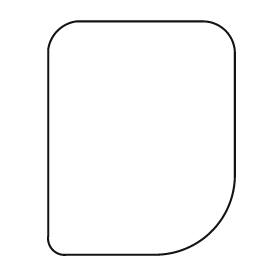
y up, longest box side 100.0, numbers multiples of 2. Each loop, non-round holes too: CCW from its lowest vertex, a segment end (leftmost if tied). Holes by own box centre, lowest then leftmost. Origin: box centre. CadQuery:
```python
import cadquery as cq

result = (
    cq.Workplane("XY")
    .moveTo(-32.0, -50.0)
    .lineTo(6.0, -50.0)
    .threePointArc((30.0, -40.0), (40.0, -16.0))
    .lineTo(40.0, 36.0)
    .threePointArc((36.0, 46.0), (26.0, 50.0))
    .lineTo(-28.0, 50.0)
    .threePointArc((-36.0, 46.0), (-40.0, 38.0))
    .lineTo(-40.0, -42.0)
    .threePointArc((-38.0, -48.0), (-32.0, -50.0))
    .close()
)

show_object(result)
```